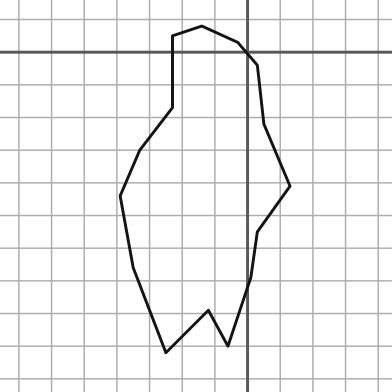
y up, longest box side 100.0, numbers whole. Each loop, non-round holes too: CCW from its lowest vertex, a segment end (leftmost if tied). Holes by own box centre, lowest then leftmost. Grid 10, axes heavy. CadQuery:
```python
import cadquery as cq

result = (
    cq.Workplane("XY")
    .moveTo(-25.0, -92.0)
    .lineTo(-12.0, -79.0)
    .lineTo(-6.0, -90.0)
    .lineTo(1.0, -69.0)
    .lineTo(3.0, -55.0)
    .lineTo(13.0, -41.0)
    .lineTo(5.0, -22.0)
    .lineTo(3.0, -4.0)
    .lineTo(-3.0, 3.0)
    .lineTo(-14.0, 8.0)
    .lineTo(-23.0, 5.0)
    .lineTo(-23.0, -17.0)
    .lineTo(-33.0, -30.0)
    .lineTo(-39.0, -44.0)
    .lineTo(-35.0, -66.0)
    .close()
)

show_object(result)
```